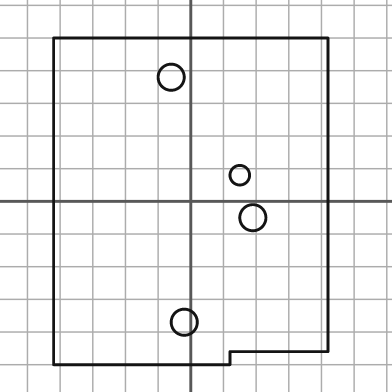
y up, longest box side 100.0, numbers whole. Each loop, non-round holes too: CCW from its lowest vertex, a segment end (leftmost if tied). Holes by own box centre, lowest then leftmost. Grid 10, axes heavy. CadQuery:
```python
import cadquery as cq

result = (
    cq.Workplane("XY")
    .moveTo(-42.0, -50.0)
    .lineTo(12.0, -50.0)
    .lineTo(12.0, -46.0)
    .lineTo(42.0, -46.0)
    .lineTo(42.0, 50.0)
    .lineTo(-42.0, 50.0)
    .close()
    .moveTo(-2.0, -37.0)
    .circle(4.0)
    .moveTo(19.0, -5.0)
    .circle(4.0)
    .moveTo(15.0, 8.0)
    .circle(3.0)
    .moveTo(-6.0, 38.0)
    .circle(4.0)
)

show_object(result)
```